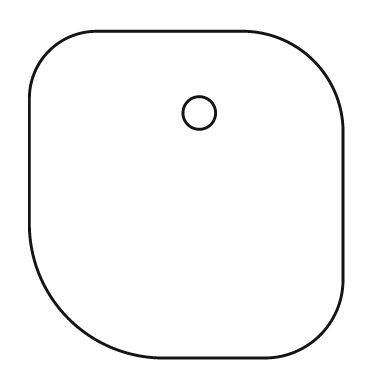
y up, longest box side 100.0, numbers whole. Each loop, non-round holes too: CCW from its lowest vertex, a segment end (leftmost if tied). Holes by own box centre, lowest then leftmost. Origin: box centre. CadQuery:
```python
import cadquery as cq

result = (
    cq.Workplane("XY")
    .moveTo(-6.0, -50.0)
    .lineTo(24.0, -50.0)
    .threePointArc((41.0, -43.0), (48.0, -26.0))
    .lineTo(48.0, 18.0)
    .threePointArc((39.0, 41.0), (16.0, 50.0))
    .lineTo(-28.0, 50.0)
    .threePointArc((-42.0, 44.0), (-48.0, 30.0))
    .lineTo(-48.0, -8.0)
    .threePointArc((-36.0, -38.0), (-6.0, -50.0))
    .close()
    .moveTo(4.0, 25.0)
    .circle(5.0)
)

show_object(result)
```